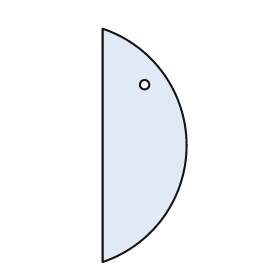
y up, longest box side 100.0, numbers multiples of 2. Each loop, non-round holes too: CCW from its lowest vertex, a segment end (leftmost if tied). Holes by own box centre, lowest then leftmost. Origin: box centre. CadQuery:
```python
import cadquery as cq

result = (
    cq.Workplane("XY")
    .moveTo(-18.0, -50.0)
    .threePointArc((18.0, 0.0), (-18.0, 50.0))
    .close()
    .moveTo(0.0, 26.0)
    .circle(2.0)
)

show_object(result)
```